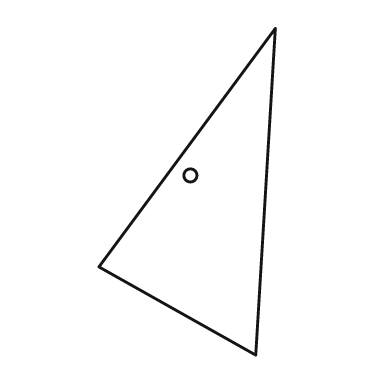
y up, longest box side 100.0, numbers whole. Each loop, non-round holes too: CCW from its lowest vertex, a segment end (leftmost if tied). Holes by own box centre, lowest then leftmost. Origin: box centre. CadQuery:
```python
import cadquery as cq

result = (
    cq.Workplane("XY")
    .moveTo(21.0, -50.0)
    .lineTo(27.0, 50.0)
    .lineTo(-27.0, -23.0)
    .close()
    .moveTo(1.0, 5.0)
    .circle(2.0)
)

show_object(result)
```